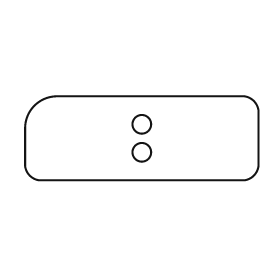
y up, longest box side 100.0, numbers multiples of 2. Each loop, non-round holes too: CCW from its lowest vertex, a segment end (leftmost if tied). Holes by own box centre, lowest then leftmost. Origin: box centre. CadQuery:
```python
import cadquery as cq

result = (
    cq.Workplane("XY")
    .moveTo(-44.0, -18.0)
    .lineTo(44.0, -18.0)
    .threePointArc((48.0, -16.0), (50.0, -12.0))
    .lineTo(50.0, 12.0)
    .threePointArc((48.0, 16.0), (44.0, 18.0))
    .lineTo(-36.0, 18.0)
    .threePointArc((-46.0, 14.0), (-50.0, 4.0))
    .lineTo(-50.0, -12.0)
    .threePointArc((-48.0, -16.0), (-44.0, -18.0))
    .close()
    .moveTo(0.0, -6.0)
    .circle(4.0)
    .moveTo(0.0, 6.0)
    .circle(4.0)
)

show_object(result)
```